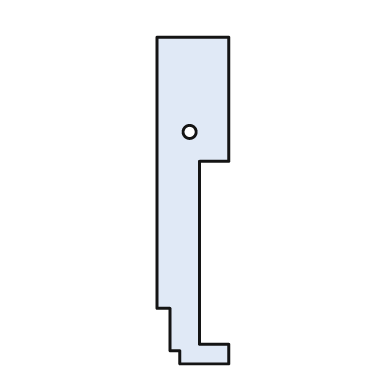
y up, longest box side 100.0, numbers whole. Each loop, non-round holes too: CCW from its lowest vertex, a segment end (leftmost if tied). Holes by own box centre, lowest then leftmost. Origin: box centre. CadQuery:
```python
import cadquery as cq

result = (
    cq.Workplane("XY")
    .moveTo(-4.0, -50.0)
    .lineTo(11.0, -50.0)
    .lineTo(11.0, -44.0)
    .lineTo(2.0, -44.0)
    .lineTo(2.0, 12.0)
    .lineTo(11.0, 12.0)
    .lineTo(11.0, 50.0)
    .lineTo(-11.0, 50.0)
    .lineTo(-11.0, -33.0)
    .lineTo(-7.0, -33.0)
    .lineTo(-7.0, -46.0)
    .lineTo(-4.0, -46.0)
    .close()
    .moveTo(-1.0, 21.0)
    .circle(2.0)
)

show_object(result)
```